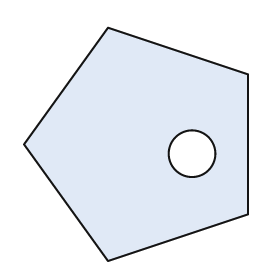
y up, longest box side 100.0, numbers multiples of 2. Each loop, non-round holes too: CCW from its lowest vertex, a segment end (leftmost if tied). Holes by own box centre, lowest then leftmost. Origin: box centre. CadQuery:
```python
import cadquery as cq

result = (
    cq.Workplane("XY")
    .moveTo(-12.0, -50.0)
    .lineTo(48.0, -30.0)
    .lineTo(48.0, 30.0)
    .lineTo(-12.0, 50.0)
    .lineTo(-48.0, 0.0)
    .close()
    .moveTo(24.0, -4.0)
    .circle(10.0)
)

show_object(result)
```